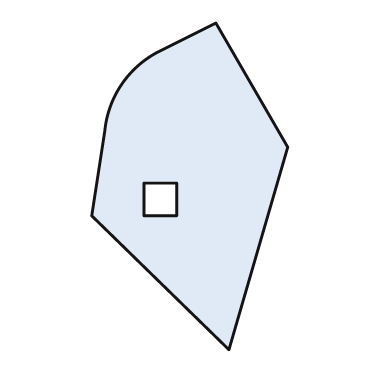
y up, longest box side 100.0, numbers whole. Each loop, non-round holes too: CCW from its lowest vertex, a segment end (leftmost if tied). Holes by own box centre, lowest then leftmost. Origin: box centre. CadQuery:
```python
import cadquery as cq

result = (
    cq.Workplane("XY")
    .moveTo(12.0, -50.0)
    .lineTo(30.0, 12.0)
    .lineTo(8.0, 50.0)
    .lineTo(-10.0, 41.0)
    .threePointArc((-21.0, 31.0), (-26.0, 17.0))
    .lineTo(-30.0, -9.0)
    .close()
    .moveTo(-14.0, -9.0)
    .lineTo(-4.0, -9.0)
    .lineTo(-4.0, 1.0)
    .lineTo(-14.0, 1.0)
    .close()
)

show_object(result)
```